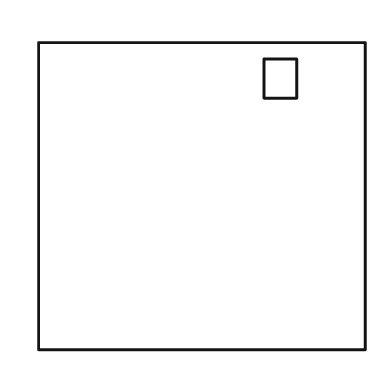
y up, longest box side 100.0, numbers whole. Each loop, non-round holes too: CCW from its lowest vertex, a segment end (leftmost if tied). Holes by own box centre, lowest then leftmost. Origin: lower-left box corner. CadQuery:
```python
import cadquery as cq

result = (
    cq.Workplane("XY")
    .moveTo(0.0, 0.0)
    .lineTo(100.0, 0.0)
    .lineTo(100.0, 94.0)
    .lineTo(0.0, 94.0)
    .close()
    .moveTo(69.0, 77.0)
    .lineTo(79.0, 77.0)
    .lineTo(79.0, 89.0)
    .lineTo(69.0, 89.0)
    .close()
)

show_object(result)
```